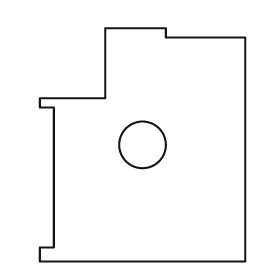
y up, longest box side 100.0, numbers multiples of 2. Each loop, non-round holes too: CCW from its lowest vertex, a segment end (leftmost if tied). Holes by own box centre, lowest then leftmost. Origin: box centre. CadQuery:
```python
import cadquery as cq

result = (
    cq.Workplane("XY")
    .moveTo(-44.0, -50.0)
    .lineTo(44.0, -50.0)
    .lineTo(44.0, 46.0)
    .lineTo(10.0, 46.0)
    .lineTo(10.0, 50.0)
    .lineTo(-16.0, 50.0)
    .lineTo(-16.0, 20.0)
    .lineTo(-44.0, 20.0)
    .lineTo(-44.0, 16.0)
    .lineTo(-38.0, 16.0)
    .lineTo(-38.0, -44.0)
    .lineTo(-44.0, -44.0)
    .close()
    .moveTo(0.0, 0.0)
    .circle(10.0)
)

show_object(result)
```